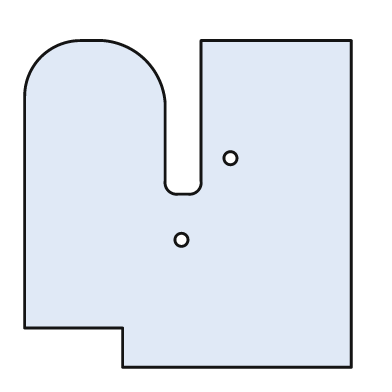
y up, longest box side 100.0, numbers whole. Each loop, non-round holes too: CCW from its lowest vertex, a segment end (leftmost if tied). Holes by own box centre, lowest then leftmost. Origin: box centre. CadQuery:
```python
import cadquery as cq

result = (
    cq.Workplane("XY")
    .moveTo(-20.0, -50.0)
    .lineTo(50.0, -50.0)
    .lineTo(50.0, 50.0)
    .lineTo(4.0, 50.0)
    .lineTo(4.0, 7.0)
    .threePointArc((3.0, 4.0), (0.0, 3.0))
    .lineTo(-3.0, 3.0)
    .threePointArc((-6.0, 4.0), (-7.0, 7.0))
    .lineTo(-7.0, 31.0)
    .threePointArc((-13.0, 44.0), (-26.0, 50.0))
    .lineTo(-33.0, 50.0)
    .threePointArc((-45.0, 45.0), (-50.0, 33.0))
    .lineTo(-50.0, -38.0)
    .lineTo(-20.0, -38.0)
    .close()
    .moveTo(-2.0, -11.0)
    .circle(2.0)
    .moveTo(13.0, 14.0)
    .circle(2.0)
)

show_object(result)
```